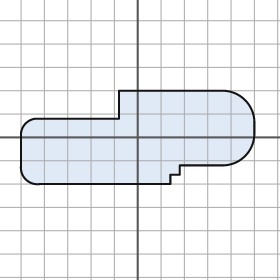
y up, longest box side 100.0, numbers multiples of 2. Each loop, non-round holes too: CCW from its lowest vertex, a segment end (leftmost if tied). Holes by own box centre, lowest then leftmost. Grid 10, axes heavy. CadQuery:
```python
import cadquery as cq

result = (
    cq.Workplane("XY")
    .moveTo(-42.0, -20.0)
    .lineTo(14.0, -20.0)
    .lineTo(14.0, -16.0)
    .lineTo(18.0, -16.0)
    .lineTo(18.0, -12.0)
    .lineTo(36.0, -12.0)
    .threePointArc((46.0, -8.0), (50.0, 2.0))
    .lineTo(50.0, 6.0)
    .threePointArc((46.0, 16.0), (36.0, 20.0))
    .lineTo(-8.0, 20.0)
    .lineTo(-8.0, 8.0)
    .lineTo(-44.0, 8.0)
    .threePointArc((-48.0, 6.0), (-50.0, 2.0))
    .lineTo(-50.0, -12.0)
    .threePointArc((-48.0, -18.0), (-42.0, -20.0))
    .close()
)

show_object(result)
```